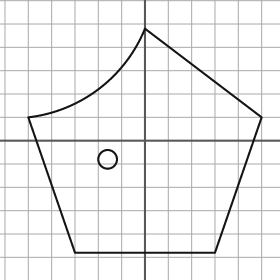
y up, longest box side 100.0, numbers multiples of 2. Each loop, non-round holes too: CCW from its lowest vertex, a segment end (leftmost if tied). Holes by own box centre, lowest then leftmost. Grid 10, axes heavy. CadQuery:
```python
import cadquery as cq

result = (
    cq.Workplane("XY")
    .moveTo(-30.0, -48.0)
    .lineTo(30.0, -48.0)
    .lineTo(50.0, 10.0)
    .lineTo(0.0, 48.0)
    .threePointArc((-20.0, 22.0), (-50.0, 10.0))
    .close()
    .moveTo(-16.0, -8.0)
    .circle(4.0)
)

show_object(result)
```